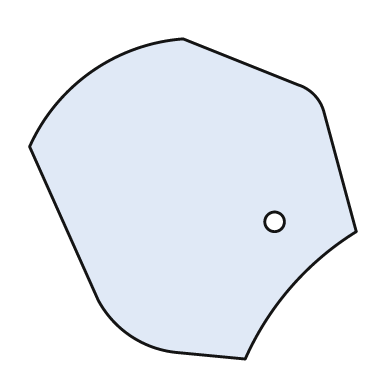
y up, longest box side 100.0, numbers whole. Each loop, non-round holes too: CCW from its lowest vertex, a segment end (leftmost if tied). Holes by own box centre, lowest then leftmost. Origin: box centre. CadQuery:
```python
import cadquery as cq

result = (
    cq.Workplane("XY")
    .moveTo(16.0, -49.0)
    .threePointArc((30.0, -27.0), (50.0, -10.0))
    .lineTo(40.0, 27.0)
    .threePointArc((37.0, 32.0), (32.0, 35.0))
    .lineTo(-3.0, 49.0)
    .threePointArc((-31.0, 39.0), (-50.0, 16.0))
    .lineTo(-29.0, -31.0)
    .threePointArc((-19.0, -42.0), (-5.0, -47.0))
    .close()
    .moveTo(25.0, -7.0)
    .circle(3.0)
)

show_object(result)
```